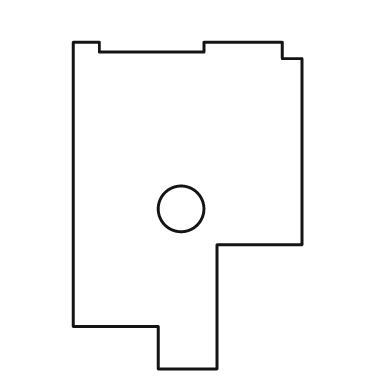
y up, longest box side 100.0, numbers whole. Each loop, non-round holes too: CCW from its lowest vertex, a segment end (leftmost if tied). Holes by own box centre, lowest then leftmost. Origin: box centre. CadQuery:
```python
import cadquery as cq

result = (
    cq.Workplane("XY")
    .moveTo(-9.0, -50.0)
    .lineTo(9.0, -50.0)
    .lineTo(9.0, -12.0)
    .lineTo(35.0, -12.0)
    .lineTo(35.0, 45.0)
    .lineTo(29.0, 45.0)
    .lineTo(29.0, 50.0)
    .lineTo(5.0, 50.0)
    .lineTo(5.0, 47.0)
    .lineTo(-27.0, 47.0)
    .lineTo(-27.0, 50.0)
    .lineTo(-35.0, 50.0)
    .lineTo(-35.0, -37.0)
    .lineTo(-9.0, -37.0)
    .close()
    .moveTo(-2.0, -1.0)
    .circle(7.0)
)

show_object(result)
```